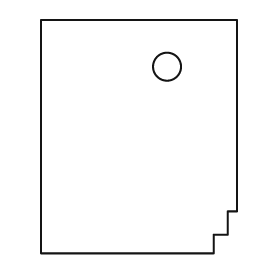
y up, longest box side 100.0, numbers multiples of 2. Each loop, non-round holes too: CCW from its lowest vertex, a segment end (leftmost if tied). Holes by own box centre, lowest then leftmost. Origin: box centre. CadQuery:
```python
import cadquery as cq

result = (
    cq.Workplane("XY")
    .moveTo(-42.0, -50.0)
    .lineTo(32.0, -50.0)
    .lineTo(32.0, -42.0)
    .lineTo(38.0, -42.0)
    .lineTo(38.0, -32.0)
    .lineTo(42.0, -32.0)
    .lineTo(42.0, 50.0)
    .lineTo(-42.0, 50.0)
    .close()
    .moveTo(12.0, 30.0)
    .circle(6.0)
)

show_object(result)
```